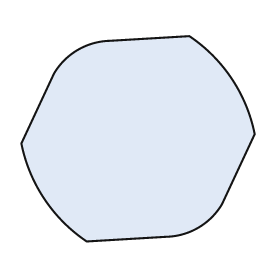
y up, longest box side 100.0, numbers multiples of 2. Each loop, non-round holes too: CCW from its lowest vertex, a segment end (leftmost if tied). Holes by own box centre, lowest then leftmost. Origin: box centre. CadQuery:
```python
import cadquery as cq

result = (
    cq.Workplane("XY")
    .moveTo(-22.0, -44.0)
    .lineTo(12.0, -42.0)
    .threePointArc((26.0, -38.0), (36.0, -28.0))
    .lineTo(50.0, 2.0)
    .threePointArc((40.0, 26.0), (22.0, 44.0))
    .lineTo(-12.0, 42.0)
    .threePointArc((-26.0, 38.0), (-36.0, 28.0))
    .lineTo(-50.0, -2.0)
    .threePointArc((-40.0, -26.0), (-22.0, -44.0))
    .close()
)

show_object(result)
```